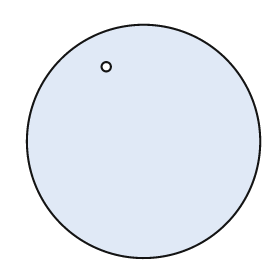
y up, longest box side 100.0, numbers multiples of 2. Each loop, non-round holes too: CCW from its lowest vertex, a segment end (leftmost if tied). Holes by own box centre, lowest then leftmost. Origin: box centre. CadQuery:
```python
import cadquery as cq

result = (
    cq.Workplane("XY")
    .moveTo(0.0, 0.0)
    .circle(50.0)
    .moveTo(-16.0, 32.0)
    .circle(2.0)
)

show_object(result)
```